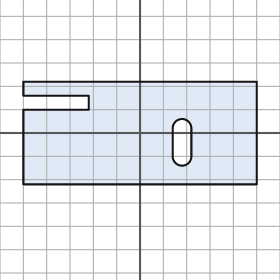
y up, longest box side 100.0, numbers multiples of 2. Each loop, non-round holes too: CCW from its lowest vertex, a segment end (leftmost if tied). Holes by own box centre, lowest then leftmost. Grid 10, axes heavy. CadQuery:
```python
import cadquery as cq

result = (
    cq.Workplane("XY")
    .moveTo(-50.0, -22.0)
    .lineTo(50.0, -22.0)
    .lineTo(50.0, 22.0)
    .lineTo(-50.0, 22.0)
    .lineTo(-50.0, 16.0)
    .lineTo(-22.0, 16.0)
    .lineTo(-22.0, 10.0)
    .lineTo(-50.0, 10.0)
    .close()
    .moveTo(14.0, -10.0)
    .threePointArc((18.0, -14.0), (22.0, -10.0))
    .lineTo(22.0, 2.0)
    .threePointArc((18.0, 6.0), (14.0, 2.0))
    .close()
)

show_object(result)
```